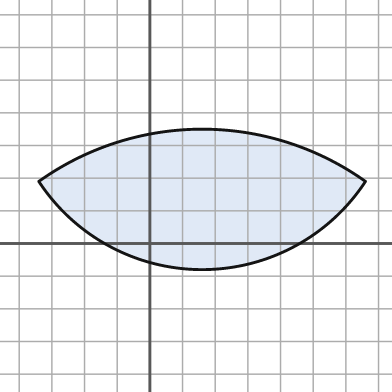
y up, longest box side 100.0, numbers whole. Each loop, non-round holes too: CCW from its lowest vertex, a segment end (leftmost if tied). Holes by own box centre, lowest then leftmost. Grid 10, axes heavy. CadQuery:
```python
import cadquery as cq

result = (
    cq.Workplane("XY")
    .moveTo(-34.0, 19.0)
    .threePointArc((16.0, -8.0), (66.0, 19.0))
    .threePointArc((16.0, 35.0), (-34.0, 19.0))
    .close()
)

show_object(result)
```